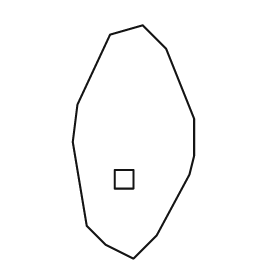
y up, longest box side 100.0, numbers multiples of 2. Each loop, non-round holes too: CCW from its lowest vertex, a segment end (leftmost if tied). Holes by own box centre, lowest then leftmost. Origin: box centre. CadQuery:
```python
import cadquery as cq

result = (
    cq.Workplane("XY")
    .moveTo(0.0, -50.0)
    .lineTo(10.0, -40.0)
    .lineTo(24.0, -14.0)
    .lineTo(26.0, -6.0)
    .lineTo(26.0, 10.0)
    .lineTo(14.0, 40.0)
    .lineTo(4.0, 50.0)
    .lineTo(-10.0, 46.0)
    .lineTo(-24.0, 16.0)
    .lineTo(-26.0, 0.0)
    .lineTo(-20.0, -36.0)
    .lineTo(-12.0, -44.0)
    .close()
    .moveTo(-8.0, -20.0)
    .lineTo(0.0, -20.0)
    .lineTo(0.0, -12.0)
    .lineTo(-8.0, -12.0)
    .close()
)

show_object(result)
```